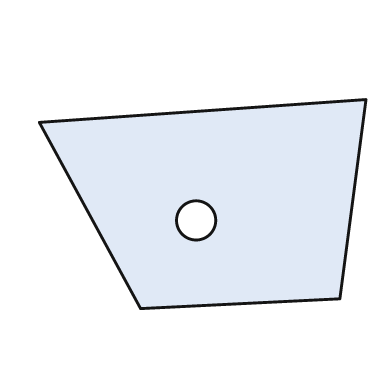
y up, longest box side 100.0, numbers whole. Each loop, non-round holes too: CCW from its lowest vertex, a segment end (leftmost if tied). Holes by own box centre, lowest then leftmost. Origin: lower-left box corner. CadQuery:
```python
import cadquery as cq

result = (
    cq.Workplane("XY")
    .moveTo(31.0, 0.0)
    .lineTo(92.0, 3.0)
    .lineTo(100.0, 64.0)
    .lineTo(0.0, 57.0)
    .close()
    .moveTo(48.0, 27.0)
    .circle(6.0)
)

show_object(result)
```